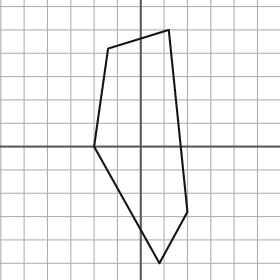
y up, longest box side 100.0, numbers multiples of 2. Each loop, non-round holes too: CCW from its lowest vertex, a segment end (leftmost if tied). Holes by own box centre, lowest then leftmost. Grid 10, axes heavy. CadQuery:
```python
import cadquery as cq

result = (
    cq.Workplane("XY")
    .moveTo(8.0, -50.0)
    .lineTo(20.0, -28.0)
    .lineTo(12.0, 50.0)
    .lineTo(-14.0, 42.0)
    .lineTo(-20.0, 0.0)
    .close()
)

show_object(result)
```